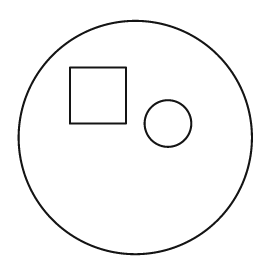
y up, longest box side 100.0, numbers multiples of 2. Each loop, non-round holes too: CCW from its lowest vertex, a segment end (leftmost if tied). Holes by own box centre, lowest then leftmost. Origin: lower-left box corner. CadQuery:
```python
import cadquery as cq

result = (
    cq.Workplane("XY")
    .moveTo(50.0, 50.0)
    .circle(50.0)
    .moveTo(64.0, 56.0)
    .circle(10.0)
    .moveTo(22.0, 56.0)
    .lineTo(46.0, 56.0)
    .lineTo(46.0, 80.0)
    .lineTo(22.0, 80.0)
    .close()
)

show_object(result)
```